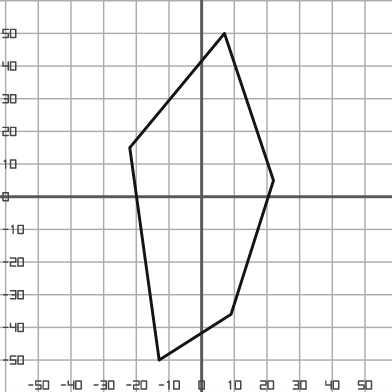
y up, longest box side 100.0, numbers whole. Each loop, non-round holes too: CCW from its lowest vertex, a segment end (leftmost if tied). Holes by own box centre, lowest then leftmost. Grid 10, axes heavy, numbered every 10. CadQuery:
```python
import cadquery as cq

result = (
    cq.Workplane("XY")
    .moveTo(-13.0, -50.0)
    .lineTo(9.0, -36.0)
    .lineTo(22.0, 5.0)
    .lineTo(7.0, 50.0)
    .lineTo(-22.0, 15.0)
    .close()
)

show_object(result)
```